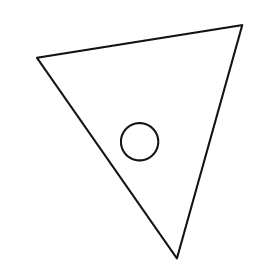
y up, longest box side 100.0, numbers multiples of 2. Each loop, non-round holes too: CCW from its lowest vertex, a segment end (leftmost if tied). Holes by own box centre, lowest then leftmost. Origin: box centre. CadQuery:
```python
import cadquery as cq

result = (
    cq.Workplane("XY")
    .moveTo(16.0, -50.0)
    .lineTo(44.0, 50.0)
    .lineTo(-44.0, 36.0)
    .close()
    .moveTo(0.0, 0.0)
    .circle(8.0)
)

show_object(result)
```